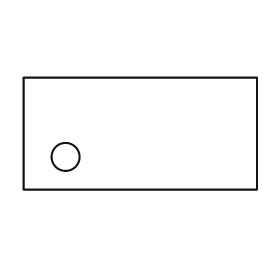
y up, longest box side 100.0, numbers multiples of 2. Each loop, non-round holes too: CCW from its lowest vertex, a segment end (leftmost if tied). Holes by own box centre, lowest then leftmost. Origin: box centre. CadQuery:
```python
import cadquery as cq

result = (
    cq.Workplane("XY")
    .moveTo(-50.0, -24.0)
    .lineTo(50.0, -24.0)
    .lineTo(50.0, 24.0)
    .lineTo(-50.0, 24.0)
    .close()
    .moveTo(-32.0, -10.0)
    .circle(6.0)
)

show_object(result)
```